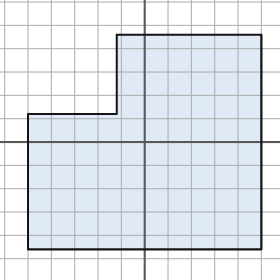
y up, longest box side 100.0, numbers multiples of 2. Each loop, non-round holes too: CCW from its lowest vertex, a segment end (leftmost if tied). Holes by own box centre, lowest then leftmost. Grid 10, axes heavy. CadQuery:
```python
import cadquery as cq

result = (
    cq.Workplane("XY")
    .moveTo(-50.0, -46.0)
    .lineTo(50.0, -46.0)
    .lineTo(50.0, 46.0)
    .lineTo(-12.0, 46.0)
    .lineTo(-12.0, 12.0)
    .lineTo(-50.0, 12.0)
    .close()
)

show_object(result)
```